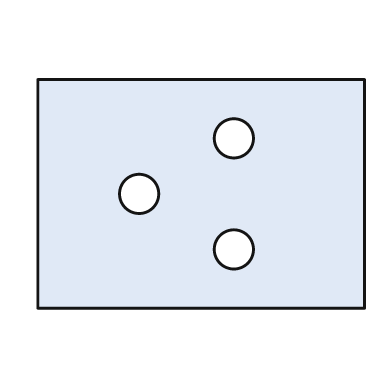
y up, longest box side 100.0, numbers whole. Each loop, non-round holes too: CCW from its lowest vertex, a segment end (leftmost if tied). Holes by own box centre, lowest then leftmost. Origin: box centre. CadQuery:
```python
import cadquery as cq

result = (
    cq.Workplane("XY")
    .moveTo(-50.0, -35.0)
    .lineTo(50.0, -35.0)
    .lineTo(50.0, 35.0)
    .lineTo(-50.0, 35.0)
    .close()
    .moveTo(10.0, -17.0)
    .circle(6.0)
    .moveTo(-19.0, 0.0)
    .circle(6.0)
    .moveTo(10.0, 17.0)
    .circle(6.0)
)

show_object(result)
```